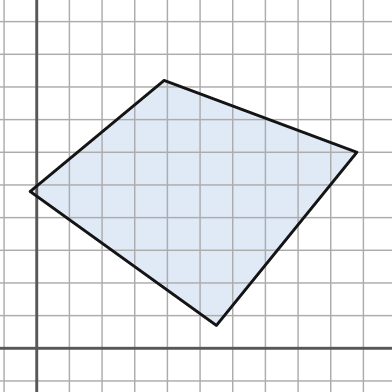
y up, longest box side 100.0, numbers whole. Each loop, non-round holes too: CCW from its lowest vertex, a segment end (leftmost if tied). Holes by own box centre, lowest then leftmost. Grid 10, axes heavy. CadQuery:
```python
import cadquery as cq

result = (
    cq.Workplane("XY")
    .moveTo(55.0, 7.0)
    .lineTo(98.0, 60.0)
    .lineTo(39.0, 82.0)
    .lineTo(-2.0, 48.0)
    .close()
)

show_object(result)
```